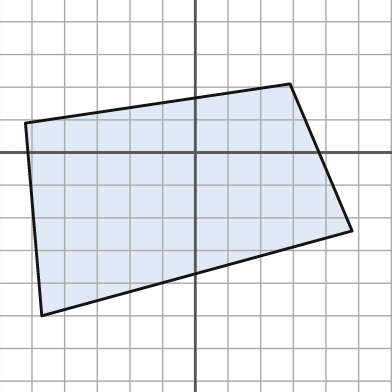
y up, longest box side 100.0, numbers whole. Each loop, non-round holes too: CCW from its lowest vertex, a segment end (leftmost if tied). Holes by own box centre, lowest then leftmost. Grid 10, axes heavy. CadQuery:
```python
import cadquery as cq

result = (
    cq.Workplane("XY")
    .moveTo(-47.0, -50.0)
    .lineTo(48.0, -24.0)
    .lineTo(29.0, 21.0)
    .lineTo(-52.0, 9.0)
    .close()
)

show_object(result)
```